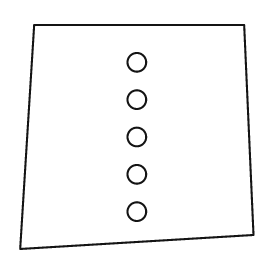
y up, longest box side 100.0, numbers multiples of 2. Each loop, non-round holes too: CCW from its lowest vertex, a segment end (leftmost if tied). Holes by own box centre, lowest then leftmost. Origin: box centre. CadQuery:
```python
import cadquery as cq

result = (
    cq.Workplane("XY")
    .moveTo(-50.0, -48.0)
    .lineTo(50.0, -42.0)
    .lineTo(46.0, 48.0)
    .lineTo(-44.0, 48.0)
    .close()
    .moveTo(0.0, -32.0)
    .circle(4.0)
    .moveTo(0.0, -16.0)
    .circle(4.0)
    .moveTo(0.0, 0.0)
    .circle(4.0)
    .moveTo(0.0, 16.0)
    .circle(4.0)
    .moveTo(0.0, 32.0)
    .circle(4.0)
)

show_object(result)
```